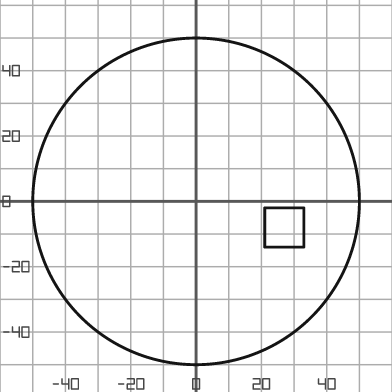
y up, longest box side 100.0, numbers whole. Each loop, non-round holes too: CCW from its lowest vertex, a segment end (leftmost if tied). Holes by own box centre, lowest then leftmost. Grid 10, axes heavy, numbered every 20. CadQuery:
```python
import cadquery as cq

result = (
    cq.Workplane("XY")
    .moveTo(0.0, 0.0)
    .circle(50.0)
    .moveTo(21.0, -14.0)
    .lineTo(33.0, -14.0)
    .lineTo(33.0, -2.0)
    .lineTo(21.0, -2.0)
    .close()
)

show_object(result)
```